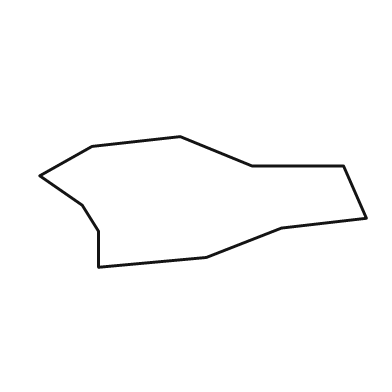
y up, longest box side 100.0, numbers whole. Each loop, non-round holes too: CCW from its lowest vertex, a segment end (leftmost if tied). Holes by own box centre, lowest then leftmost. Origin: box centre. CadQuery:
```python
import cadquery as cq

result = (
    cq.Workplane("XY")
    .moveTo(-32.0, -20.0)
    .lineTo(1.0, -17.0)
    .lineTo(24.0, -8.0)
    .lineTo(50.0, -5.0)
    .lineTo(43.0, 11.0)
    .lineTo(15.0, 11.0)
    .lineTo(-7.0, 20.0)
    .lineTo(-34.0, 17.0)
    .lineTo(-50.0, 8.0)
    .lineTo(-37.0, -1.0)
    .lineTo(-32.0, -9.0)
    .close()
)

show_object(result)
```